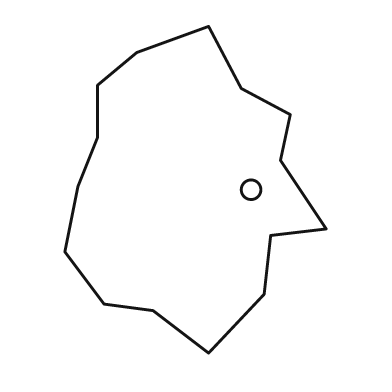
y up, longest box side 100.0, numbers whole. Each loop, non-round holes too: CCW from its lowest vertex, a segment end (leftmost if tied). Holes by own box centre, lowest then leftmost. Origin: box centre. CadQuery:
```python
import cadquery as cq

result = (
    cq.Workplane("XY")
    .moveTo(4.0, -50.0)
    .lineTo(21.0, -32.0)
    .lineTo(23.0, -14.0)
    .lineTo(40.0, -12.0)
    .lineTo(26.0, 9.0)
    .lineTo(29.0, 23.0)
    .lineTo(14.0, 31.0)
    .lineTo(4.0, 50.0)
    .lineTo(-18.0, 42.0)
    .lineTo(-30.0, 32.0)
    .lineTo(-30.0, 16.0)
    .lineTo(-36.0, 1.0)
    .lineTo(-40.0, -19.0)
    .lineTo(-28.0, -35.0)
    .lineTo(-13.0, -37.0)
    .close()
    .moveTo(17.0, 0.0)
    .circle(3.0)
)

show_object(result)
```